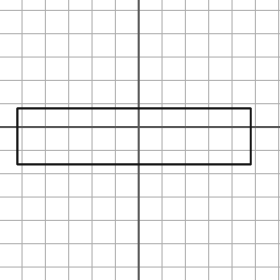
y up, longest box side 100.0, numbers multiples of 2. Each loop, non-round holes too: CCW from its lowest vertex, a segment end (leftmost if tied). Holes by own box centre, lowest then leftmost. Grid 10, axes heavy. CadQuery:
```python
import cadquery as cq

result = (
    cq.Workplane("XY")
    .moveTo(-52.0, -16.0)
    .lineTo(48.0, -16.0)
    .lineTo(48.0, 8.0)
    .lineTo(-52.0, 8.0)
    .close()
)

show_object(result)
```